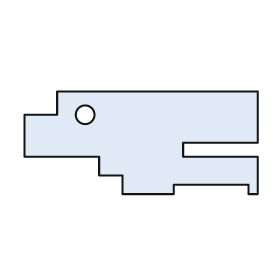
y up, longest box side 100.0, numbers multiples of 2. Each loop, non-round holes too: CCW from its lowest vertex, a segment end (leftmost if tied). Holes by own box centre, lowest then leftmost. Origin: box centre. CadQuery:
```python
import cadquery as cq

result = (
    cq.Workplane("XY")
    .moveTo(-8.0, -22.0)
    .lineTo(14.0, -22.0)
    .lineTo(14.0, -18.0)
    .lineTo(46.0, -18.0)
    .lineTo(46.0, -22.0)
    .lineTo(50.0, -22.0)
    .lineTo(50.0, -6.0)
    .lineTo(18.0, -6.0)
    .lineTo(18.0, 0.0)
    .lineTo(50.0, 0.0)
    .lineTo(50.0, 22.0)
    .lineTo(-36.0, 22.0)
    .lineTo(-36.0, 12.0)
    .lineTo(-50.0, 12.0)
    .lineTo(-50.0, -6.0)
    .lineTo(-18.0, -6.0)
    .lineTo(-18.0, -14.0)
    .lineTo(-8.0, -14.0)
    .close()
    .moveTo(-24.0, 12.0)
    .circle(4.0)
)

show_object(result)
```